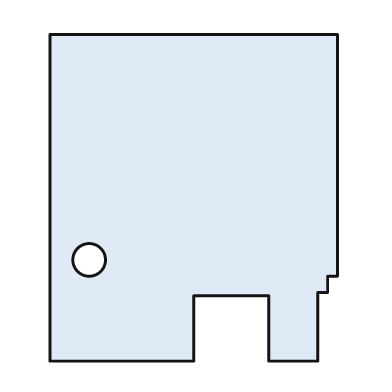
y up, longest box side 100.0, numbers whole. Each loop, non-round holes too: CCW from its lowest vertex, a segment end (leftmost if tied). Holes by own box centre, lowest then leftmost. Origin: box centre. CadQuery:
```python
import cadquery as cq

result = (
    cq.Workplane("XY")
    .moveTo(-44.0, -50.0)
    .lineTo(0.0, -50.0)
    .lineTo(0.0, -30.0)
    .lineTo(23.0, -30.0)
    .lineTo(23.0, -50.0)
    .lineTo(38.0, -50.0)
    .lineTo(38.0, -29.0)
    .lineTo(41.0, -29.0)
    .lineTo(41.0, -24.0)
    .lineTo(44.0, -24.0)
    .lineTo(44.0, 50.0)
    .lineTo(-44.0, 50.0)
    .close()
    .moveTo(-32.0, -19.0)
    .circle(5.0)
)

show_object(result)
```